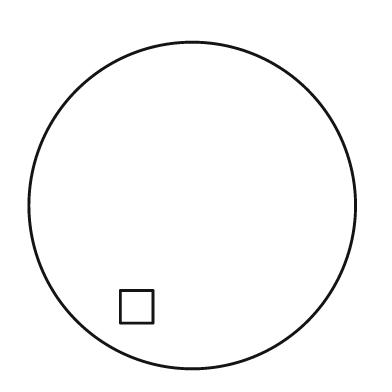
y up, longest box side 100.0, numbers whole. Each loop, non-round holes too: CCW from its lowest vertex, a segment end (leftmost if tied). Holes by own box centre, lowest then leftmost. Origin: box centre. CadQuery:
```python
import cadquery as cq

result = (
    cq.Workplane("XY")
    .moveTo(0.0, 0.0)
    .circle(50.0)
    .moveTo(-22.0, -36.0)
    .lineTo(-12.0, -36.0)
    .lineTo(-12.0, -26.0)
    .lineTo(-22.0, -26.0)
    .close()
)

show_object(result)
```